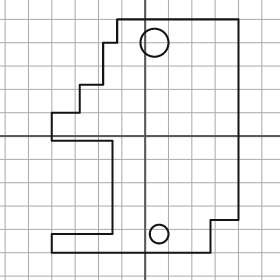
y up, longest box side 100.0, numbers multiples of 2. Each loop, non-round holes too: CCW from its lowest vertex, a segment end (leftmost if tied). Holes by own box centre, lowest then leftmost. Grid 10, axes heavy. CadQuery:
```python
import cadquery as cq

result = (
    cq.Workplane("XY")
    .moveTo(-40.0, -50.0)
    .lineTo(28.0, -50.0)
    .lineTo(28.0, -36.0)
    .lineTo(40.0, -36.0)
    .lineTo(40.0, 50.0)
    .lineTo(-12.0, 50.0)
    .lineTo(-12.0, 40.0)
    .lineTo(-18.0, 40.0)
    .lineTo(-18.0, 22.0)
    .lineTo(-28.0, 22.0)
    .lineTo(-28.0, 10.0)
    .lineTo(-40.0, 10.0)
    .lineTo(-40.0, -2.0)
    .lineTo(-14.0, -2.0)
    .lineTo(-14.0, -42.0)
    .lineTo(-40.0, -42.0)
    .close()
    .moveTo(6.0, -42.0)
    .circle(4.0)
    .moveTo(4.0, 40.0)
    .circle(6.0)
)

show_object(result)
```